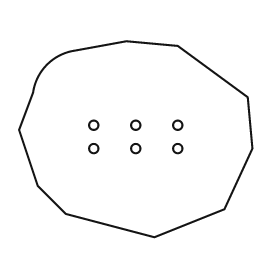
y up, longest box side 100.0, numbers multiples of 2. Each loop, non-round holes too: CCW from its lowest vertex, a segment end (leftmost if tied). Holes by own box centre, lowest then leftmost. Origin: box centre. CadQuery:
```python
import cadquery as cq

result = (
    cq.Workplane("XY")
    .moveTo(8.0, -42.0)
    .lineTo(38.0, -30.0)
    .lineTo(50.0, -4.0)
    .lineTo(48.0, 18.0)
    .lineTo(18.0, 40.0)
    .lineTo(-4.0, 42.0)
    .lineTo(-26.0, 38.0)
    .threePointArc((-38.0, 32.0), (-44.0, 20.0))
    .lineTo(-50.0, 4.0)
    .lineTo(-42.0, -20.0)
    .lineTo(-30.0, -32.0)
    .close()
    .moveTo(-18.0, -4.0)
    .circle(2.0)
    .moveTo(0.0, -4.0)
    .circle(2.0)
    .moveTo(18.0, -4.0)
    .circle(2.0)
    .moveTo(-18.0, 6.0)
    .circle(2.0)
    .moveTo(0.0, 6.0)
    .circle(2.0)
    .moveTo(18.0, 6.0)
    .circle(2.0)
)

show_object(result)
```